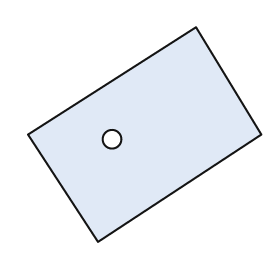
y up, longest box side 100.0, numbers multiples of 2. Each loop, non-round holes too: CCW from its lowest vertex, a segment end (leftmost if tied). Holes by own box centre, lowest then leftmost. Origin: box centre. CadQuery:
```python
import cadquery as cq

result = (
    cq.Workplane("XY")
    .moveTo(-20.0, -46.0)
    .lineTo(50.0, 0.0)
    .lineTo(22.0, 46.0)
    .lineTo(-50.0, 0.0)
    .close()
    .moveTo(-14.0, -2.0)
    .circle(4.0)
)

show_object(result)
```